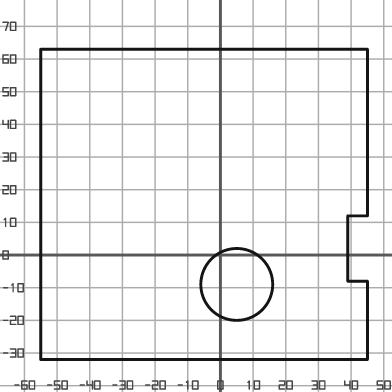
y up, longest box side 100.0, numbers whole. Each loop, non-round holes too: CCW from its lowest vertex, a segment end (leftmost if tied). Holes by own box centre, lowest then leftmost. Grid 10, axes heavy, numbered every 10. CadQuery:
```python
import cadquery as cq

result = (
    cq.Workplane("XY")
    .moveTo(-55.0, -32.0)
    .lineTo(45.0, -32.0)
    .lineTo(45.0, -8.0)
    .lineTo(39.0, -8.0)
    .lineTo(39.0, 12.0)
    .lineTo(45.0, 12.0)
    .lineTo(45.0, 63.0)
    .lineTo(-55.0, 63.0)
    .close()
    .moveTo(5.0, -9.0)
    .circle(11.0)
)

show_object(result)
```